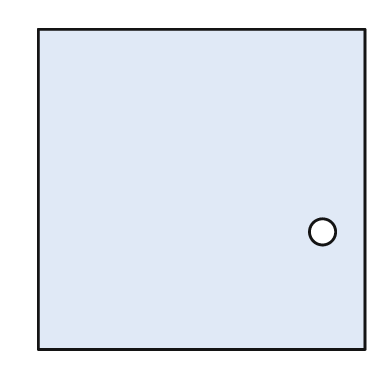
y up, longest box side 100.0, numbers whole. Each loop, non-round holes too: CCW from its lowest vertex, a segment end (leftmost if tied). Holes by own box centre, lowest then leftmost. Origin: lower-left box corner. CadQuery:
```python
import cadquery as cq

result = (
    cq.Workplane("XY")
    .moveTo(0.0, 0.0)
    .lineTo(100.0, 0.0)
    .lineTo(100.0, 98.0)
    .lineTo(0.0, 98.0)
    .close()
    .moveTo(87.0, 36.0)
    .circle(4.0)
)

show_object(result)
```